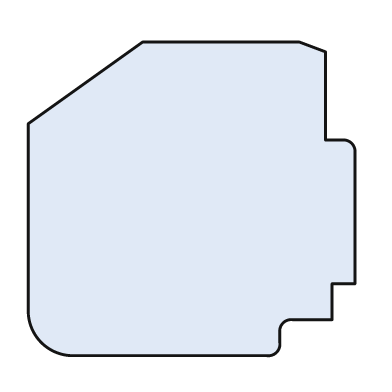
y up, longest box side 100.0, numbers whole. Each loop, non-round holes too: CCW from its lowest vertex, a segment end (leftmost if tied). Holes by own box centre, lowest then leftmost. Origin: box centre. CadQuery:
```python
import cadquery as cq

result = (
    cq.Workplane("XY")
    .moveTo(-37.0, -48.0)
    .lineTo(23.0, -48.0)
    .threePointArc((26.0, -47.0), (27.0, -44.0))
    .lineTo(27.0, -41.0)
    .threePointArc((28.0, -38.0), (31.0, -37.0))
    .lineTo(43.0, -37.0)
    .lineTo(43.0, -26.0)
    .lineTo(50.0, -26.0)
    .lineTo(50.0, 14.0)
    .threePointArc((49.0, 17.0), (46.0, 18.0))
    .lineTo(41.0, 18.0)
    .lineTo(41.0, 45.0)
    .lineTo(33.0, 48.0)
    .lineTo(-15.0, 48.0)
    .lineTo(-50.0, 23.0)
    .lineTo(-50.0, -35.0)
    .threePointArc((-46.0, -44.0), (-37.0, -48.0))
    .close()
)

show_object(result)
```